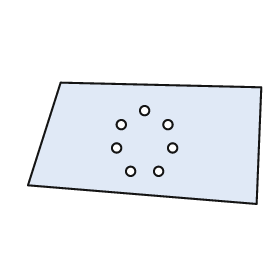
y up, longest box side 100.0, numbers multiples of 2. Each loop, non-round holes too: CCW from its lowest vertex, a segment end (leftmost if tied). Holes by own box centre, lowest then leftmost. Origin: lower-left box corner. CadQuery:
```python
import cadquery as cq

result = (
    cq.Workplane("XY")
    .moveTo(98.0, 0.0)
    .lineTo(100.0, 50.0)
    .lineTo(14.0, 52.0)
    .lineTo(0.0, 8.0)
    .close()
    .moveTo(44.0, 14.0)
    .circle(2.0)
    .moveTo(56.0, 14.0)
    .circle(2.0)
    .moveTo(38.0, 24.0)
    .circle(2.0)
    .moveTo(62.0, 24.0)
    .circle(2.0)
    .moveTo(40.0, 34.0)
    .circle(2.0)
    .moveTo(60.0, 34.0)
    .circle(2.0)
    .moveTo(50.0, 40.0)
    .circle(2.0)
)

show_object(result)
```